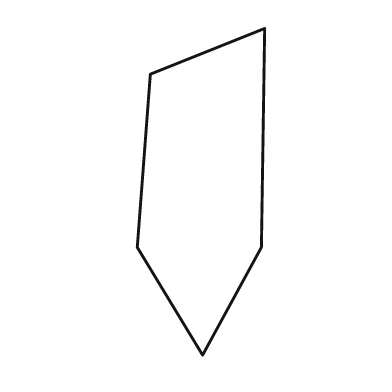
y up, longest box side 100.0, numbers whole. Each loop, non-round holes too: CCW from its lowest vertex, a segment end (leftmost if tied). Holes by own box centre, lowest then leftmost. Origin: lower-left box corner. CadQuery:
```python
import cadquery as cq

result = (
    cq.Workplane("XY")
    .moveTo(20.0, 0.0)
    .lineTo(38.0, 33.0)
    .lineTo(39.0, 100.0)
    .lineTo(4.0, 86.0)
    .lineTo(0.0, 33.0)
    .close()
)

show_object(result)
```